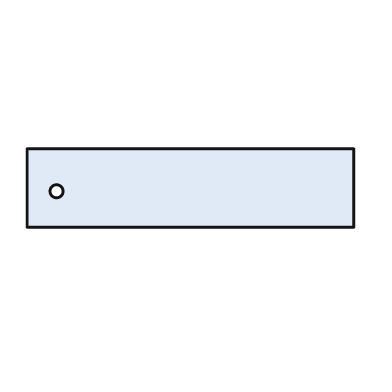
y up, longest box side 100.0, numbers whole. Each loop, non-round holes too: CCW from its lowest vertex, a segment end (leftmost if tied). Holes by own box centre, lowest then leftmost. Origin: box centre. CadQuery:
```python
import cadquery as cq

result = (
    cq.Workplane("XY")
    .moveTo(-50.0, -12.0)
    .lineTo(50.0, -12.0)
    .lineTo(50.0, 12.0)
    .lineTo(-50.0, 12.0)
    .close()
    .moveTo(-41.0, -1.0)
    .circle(2.0)
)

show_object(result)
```